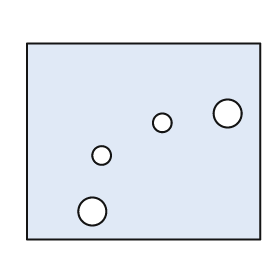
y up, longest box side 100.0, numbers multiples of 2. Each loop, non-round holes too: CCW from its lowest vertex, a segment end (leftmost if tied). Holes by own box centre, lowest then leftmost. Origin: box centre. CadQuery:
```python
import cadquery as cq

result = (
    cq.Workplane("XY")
    .moveTo(-50.0, -42.0)
    .lineTo(50.0, -42.0)
    .lineTo(50.0, 42.0)
    .lineTo(-50.0, 42.0)
    .close()
    .moveTo(-22.0, -30.0)
    .circle(6.0)
    .moveTo(-18.0, -6.0)
    .circle(4.0)
    .moveTo(8.0, 8.0)
    .circle(4.0)
    .moveTo(36.0, 12.0)
    .circle(6.0)
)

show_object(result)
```